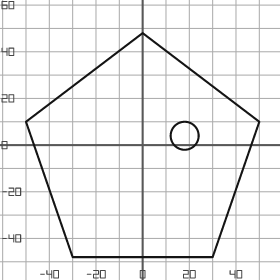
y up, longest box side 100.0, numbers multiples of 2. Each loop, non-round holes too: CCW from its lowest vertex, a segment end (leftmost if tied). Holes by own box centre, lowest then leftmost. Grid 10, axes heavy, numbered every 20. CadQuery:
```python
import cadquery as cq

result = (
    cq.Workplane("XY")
    .moveTo(-30.0, -48.0)
    .lineTo(30.0, -48.0)
    .lineTo(50.0, 10.0)
    .lineTo(0.0, 48.0)
    .lineTo(-50.0, 10.0)
    .close()
    .moveTo(18.0, 4.0)
    .circle(6.0)
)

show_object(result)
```